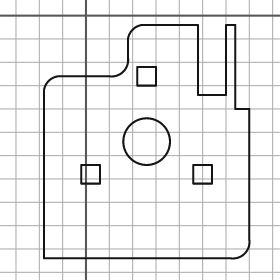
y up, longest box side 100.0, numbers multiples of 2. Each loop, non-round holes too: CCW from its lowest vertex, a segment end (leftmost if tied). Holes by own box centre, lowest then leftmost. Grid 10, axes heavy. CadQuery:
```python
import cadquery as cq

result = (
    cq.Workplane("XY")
    .moveTo(-18.0, -104.0)
    .lineTo(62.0, -104.0)
    .threePointArc((68.0, -102.0), (70.0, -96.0))
    .lineTo(70.0, -40.0)
    .lineTo(64.0, -40.0)
    .lineTo(64.0, -4.0)
    .lineTo(60.0, -4.0)
    .lineTo(60.0, -34.0)
    .lineTo(48.0, -34.0)
    .lineTo(48.0, -4.0)
    .lineTo(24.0, -4.0)
    .threePointArc((20.0, -6.0), (18.0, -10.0))
    .lineTo(18.0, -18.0)
    .threePointArc((16.0, -24.0), (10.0, -26.0))
    .lineTo(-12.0, -26.0)
    .threePointArc((-16.0, -28.0), (-18.0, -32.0))
    .close()
    .moveTo(-2.0, -72.0)
    .lineTo(6.0, -72.0)
    .lineTo(6.0, -64.0)
    .lineTo(-2.0, -64.0)
    .close()
    .moveTo(46.0, -72.0)
    .lineTo(54.0, -72.0)
    .lineTo(54.0, -64.0)
    .lineTo(46.0, -64.0)
    .close()
    .moveTo(26.0, -54.0)
    .circle(10.0)
    .moveTo(22.0, -30.0)
    .lineTo(30.0, -30.0)
    .lineTo(30.0, -22.0)
    .lineTo(22.0, -22.0)
    .close()
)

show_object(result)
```